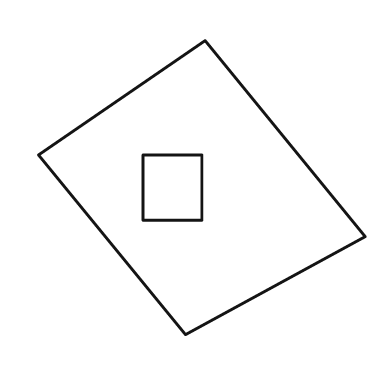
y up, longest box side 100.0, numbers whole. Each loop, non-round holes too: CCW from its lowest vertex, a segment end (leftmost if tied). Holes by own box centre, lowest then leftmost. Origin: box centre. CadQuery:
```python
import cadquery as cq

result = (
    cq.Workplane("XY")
    .moveTo(-5.0, -45.0)
    .lineTo(50.0, -15.0)
    .lineTo(1.0, 45.0)
    .lineTo(-50.0, 10.0)
    .close()
    .moveTo(-18.0, -10.0)
    .lineTo(0.0, -10.0)
    .lineTo(0.0, 10.0)
    .lineTo(-18.0, 10.0)
    .close()
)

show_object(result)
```